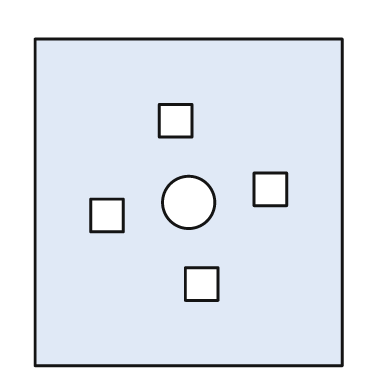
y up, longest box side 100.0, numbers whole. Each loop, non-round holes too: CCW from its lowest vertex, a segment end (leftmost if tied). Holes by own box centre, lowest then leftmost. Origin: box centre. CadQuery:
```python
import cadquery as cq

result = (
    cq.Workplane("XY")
    .moveTo(-47.0, -50.0)
    .lineTo(47.0, -50.0)
    .lineTo(47.0, 50.0)
    .lineTo(-47.0, 50.0)
    .close()
    .moveTo(-1.0, -30.0)
    .lineTo(9.0, -30.0)
    .lineTo(9.0, -20.0)
    .lineTo(-1.0, -20.0)
    .close()
    .moveTo(-30.0, -9.0)
    .lineTo(-20.0, -9.0)
    .lineTo(-20.0, 1.0)
    .lineTo(-30.0, 1.0)
    .close()
    .moveTo(0.0, 0.0)
    .circle(8.0)
    .moveTo(20.0, -1.0)
    .lineTo(30.0, -1.0)
    .lineTo(30.0, 9.0)
    .lineTo(20.0, 9.0)
    .close()
    .moveTo(-9.0, 20.0)
    .lineTo(1.0, 20.0)
    .lineTo(1.0, 30.0)
    .lineTo(-9.0, 30.0)
    .close()
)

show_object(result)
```